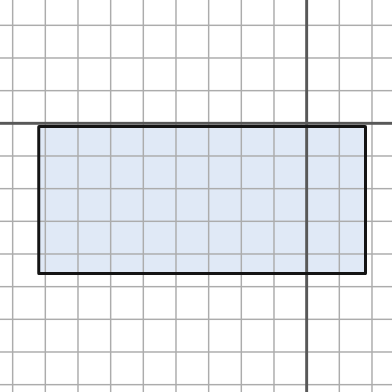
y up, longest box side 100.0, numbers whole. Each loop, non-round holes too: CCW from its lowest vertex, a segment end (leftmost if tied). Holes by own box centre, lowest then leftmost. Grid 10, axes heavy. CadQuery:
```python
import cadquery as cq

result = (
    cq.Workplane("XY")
    .moveTo(-82.0, -46.0)
    .lineTo(18.0, -46.0)
    .lineTo(18.0, -1.0)
    .lineTo(-82.0, -1.0)
    .close()
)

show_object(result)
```